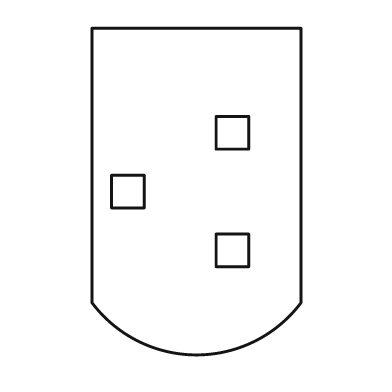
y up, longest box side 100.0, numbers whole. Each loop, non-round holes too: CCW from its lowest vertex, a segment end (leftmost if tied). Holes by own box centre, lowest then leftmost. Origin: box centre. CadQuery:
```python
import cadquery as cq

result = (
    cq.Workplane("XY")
    .moveTo(-32.0, -34.0)
    .threePointArc((0.0, -50.0), (32.0, -34.0))
    .lineTo(32.0, 50.0)
    .lineTo(-32.0, 50.0)
    .close()
    .moveTo(6.0, -23.0)
    .lineTo(16.0, -23.0)
    .lineTo(16.0, -13.0)
    .lineTo(6.0, -13.0)
    .close()
    .moveTo(-26.0, -5.0)
    .lineTo(-16.0, -5.0)
    .lineTo(-16.0, 5.0)
    .lineTo(-26.0, 5.0)
    .close()
    .moveTo(6.0, 13.0)
    .lineTo(16.0, 13.0)
    .lineTo(16.0, 23.0)
    .lineTo(6.0, 23.0)
    .close()
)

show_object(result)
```